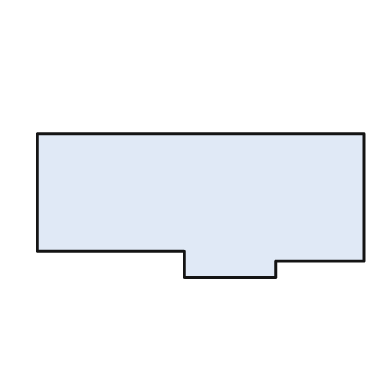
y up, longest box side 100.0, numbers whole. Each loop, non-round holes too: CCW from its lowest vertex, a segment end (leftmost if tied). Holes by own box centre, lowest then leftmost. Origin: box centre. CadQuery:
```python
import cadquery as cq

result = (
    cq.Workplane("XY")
    .moveTo(-5.0, -22.0)
    .lineTo(23.0, -22.0)
    .lineTo(23.0, -17.0)
    .lineTo(50.0, -17.0)
    .lineTo(50.0, 22.0)
    .lineTo(-50.0, 22.0)
    .lineTo(-50.0, -14.0)
    .lineTo(-5.0, -14.0)
    .close()
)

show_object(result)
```